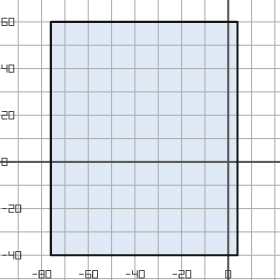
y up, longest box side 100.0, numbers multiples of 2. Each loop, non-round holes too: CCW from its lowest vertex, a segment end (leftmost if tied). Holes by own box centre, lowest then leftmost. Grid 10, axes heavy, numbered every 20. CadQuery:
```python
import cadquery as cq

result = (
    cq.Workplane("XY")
    .moveTo(-76.0, -40.0)
    .lineTo(4.0, -40.0)
    .lineTo(4.0, 60.0)
    .lineTo(-76.0, 60.0)
    .close()
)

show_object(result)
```